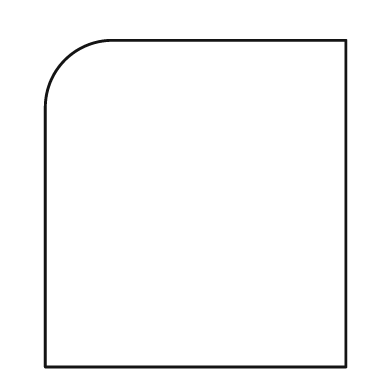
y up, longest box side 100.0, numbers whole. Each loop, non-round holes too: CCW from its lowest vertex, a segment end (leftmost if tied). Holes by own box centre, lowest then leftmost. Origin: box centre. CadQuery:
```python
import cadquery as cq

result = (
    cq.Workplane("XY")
    .moveTo(-46.0, -50.0)
    .lineTo(46.0, -50.0)
    .lineTo(46.0, 50.0)
    .lineTo(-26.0, 50.0)
    .threePointArc((-40.0, 44.0), (-46.0, 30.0))
    .close()
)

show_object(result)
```